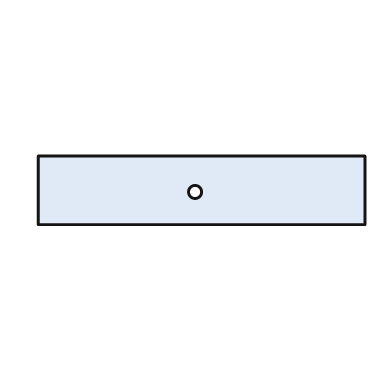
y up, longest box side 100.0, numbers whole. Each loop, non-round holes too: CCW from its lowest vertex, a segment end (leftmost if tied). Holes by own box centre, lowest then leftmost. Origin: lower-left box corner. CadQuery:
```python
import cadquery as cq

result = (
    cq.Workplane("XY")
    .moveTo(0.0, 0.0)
    .lineTo(100.0, 0.0)
    .lineTo(100.0, 21.0)
    .lineTo(0.0, 21.0)
    .close()
    .moveTo(48.0, 10.0)
    .circle(2.0)
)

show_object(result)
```